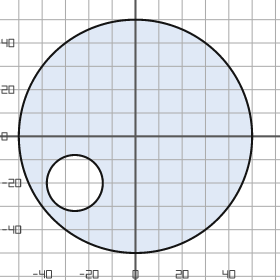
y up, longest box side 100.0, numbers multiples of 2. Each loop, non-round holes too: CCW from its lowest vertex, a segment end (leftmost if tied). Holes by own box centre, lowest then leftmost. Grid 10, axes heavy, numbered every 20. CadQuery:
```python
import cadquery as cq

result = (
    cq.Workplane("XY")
    .moveTo(0.0, 0.0)
    .circle(50.0)
    .moveTo(-26.0, -20.0)
    .circle(12.0)
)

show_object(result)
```